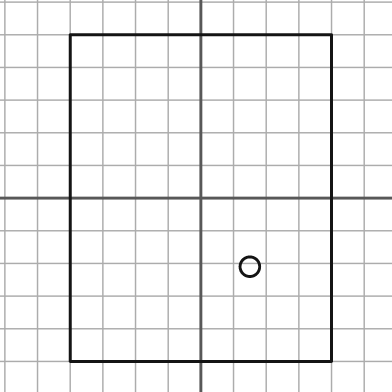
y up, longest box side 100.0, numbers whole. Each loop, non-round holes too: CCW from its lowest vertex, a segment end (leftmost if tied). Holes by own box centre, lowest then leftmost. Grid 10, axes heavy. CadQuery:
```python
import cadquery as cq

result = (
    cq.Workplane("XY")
    .moveTo(-40.0, -50.0)
    .lineTo(40.0, -50.0)
    .lineTo(40.0, 50.0)
    .lineTo(-40.0, 50.0)
    .close()
    .moveTo(15.0, -21.0)
    .circle(3.0)
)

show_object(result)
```